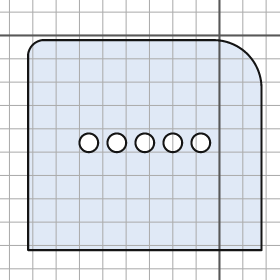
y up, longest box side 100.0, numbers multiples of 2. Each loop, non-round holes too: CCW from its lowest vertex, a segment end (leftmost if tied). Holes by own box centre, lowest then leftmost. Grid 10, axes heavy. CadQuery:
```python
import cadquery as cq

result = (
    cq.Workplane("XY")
    .moveTo(-82.0, -92.0)
    .lineTo(18.0, -92.0)
    .lineTo(18.0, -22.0)
    .threePointArc((12.0, -8.0), (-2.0, -2.0))
    .lineTo(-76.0, -2.0)
    .threePointArc((-80.0, -4.0), (-82.0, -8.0))
    .close()
    .moveTo(-56.0, -46.0)
    .circle(4.0)
    .moveTo(-44.0, -46.0)
    .circle(4.0)
    .moveTo(-32.0, -46.0)
    .circle(4.0)
    .moveTo(-20.0, -46.0)
    .circle(4.0)
    .moveTo(-8.0, -46.0)
    .circle(4.0)
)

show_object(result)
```